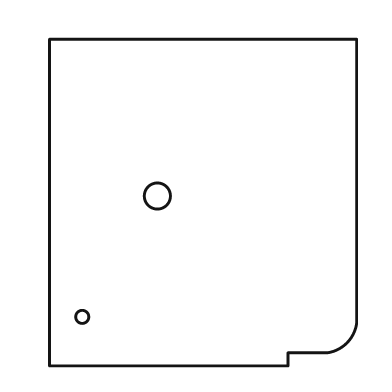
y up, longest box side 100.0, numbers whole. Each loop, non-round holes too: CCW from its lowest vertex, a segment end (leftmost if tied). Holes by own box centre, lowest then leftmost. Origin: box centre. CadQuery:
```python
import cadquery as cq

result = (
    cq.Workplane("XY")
    .moveTo(-47.0, -50.0)
    .lineTo(26.0, -50.0)
    .lineTo(26.0, -46.0)
    .lineTo(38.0, -46.0)
    .threePointArc((44.0, -43.0), (47.0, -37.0))
    .lineTo(47.0, 50.0)
    .lineTo(-47.0, 50.0)
    .close()
    .moveTo(-37.0, -35.0)
    .circle(2.0)
    .moveTo(-14.0, 2.0)
    .circle(4.0)
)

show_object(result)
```